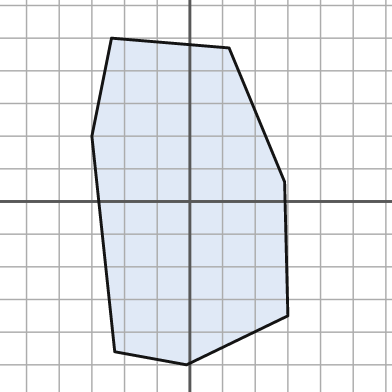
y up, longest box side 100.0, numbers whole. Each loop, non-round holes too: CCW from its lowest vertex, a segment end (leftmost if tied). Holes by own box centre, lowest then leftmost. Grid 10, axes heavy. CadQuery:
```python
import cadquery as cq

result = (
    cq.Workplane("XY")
    .moveTo(-1.0, -50.0)
    .lineTo(30.0, -35.0)
    .lineTo(29.0, 6.0)
    .lineTo(12.0, 47.0)
    .lineTo(-24.0, 50.0)
    .lineTo(-30.0, 20.0)
    .lineTo(-23.0, -46.0)
    .close()
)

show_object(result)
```